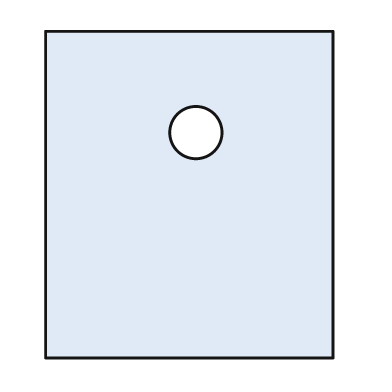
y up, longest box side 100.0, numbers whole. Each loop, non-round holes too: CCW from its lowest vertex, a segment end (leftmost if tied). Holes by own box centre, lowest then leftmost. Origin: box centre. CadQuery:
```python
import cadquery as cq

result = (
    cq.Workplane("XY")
    .moveTo(-44.0, -50.0)
    .lineTo(44.0, -50.0)
    .lineTo(44.0, 50.0)
    .lineTo(-44.0, 50.0)
    .close()
    .moveTo(2.0, 19.0)
    .circle(8.0)
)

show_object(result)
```